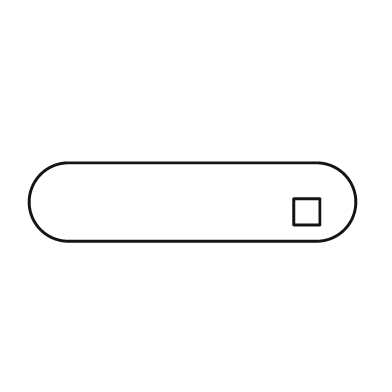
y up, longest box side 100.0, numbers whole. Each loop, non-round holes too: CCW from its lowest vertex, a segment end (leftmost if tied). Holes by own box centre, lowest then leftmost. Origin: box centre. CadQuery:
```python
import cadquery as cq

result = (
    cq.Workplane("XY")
    .moveTo(-38.0, -12.0)
    .lineTo(38.0, -12.0)
    .threePointArc((50.0, 0.0), (38.0, 12.0))
    .lineTo(-38.0, 12.0)
    .threePointArc((-50.0, 0.0), (-38.0, -12.0))
    .close()
    .moveTo(31.0, -7.0)
    .lineTo(39.0, -7.0)
    .lineTo(39.0, 1.0)
    .lineTo(31.0, 1.0)
    .close()
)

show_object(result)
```